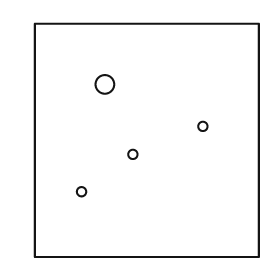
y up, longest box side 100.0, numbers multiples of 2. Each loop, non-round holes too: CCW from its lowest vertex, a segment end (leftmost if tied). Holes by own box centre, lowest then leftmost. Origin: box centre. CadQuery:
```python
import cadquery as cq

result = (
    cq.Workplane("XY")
    .moveTo(-48.0, -50.0)
    .lineTo(48.0, -50.0)
    .lineTo(48.0, 50.0)
    .lineTo(-48.0, 50.0)
    .close()
    .moveTo(-28.0, -22.0)
    .circle(2.0)
    .moveTo(-6.0, -6.0)
    .circle(2.0)
    .moveTo(24.0, 6.0)
    .circle(2.0)
    .moveTo(-18.0, 24.0)
    .circle(4.0)
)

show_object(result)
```